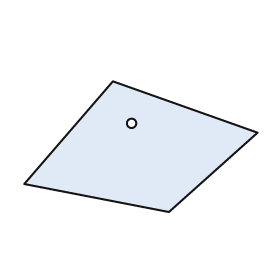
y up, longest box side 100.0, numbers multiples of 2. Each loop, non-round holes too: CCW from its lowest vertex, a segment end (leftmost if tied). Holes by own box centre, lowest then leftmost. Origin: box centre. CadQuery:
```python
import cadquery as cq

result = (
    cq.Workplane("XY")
    .moveTo(12.0, -28.0)
    .lineTo(50.0, 6.0)
    .lineTo(-12.0, 28.0)
    .lineTo(-50.0, -16.0)
    .close()
    .moveTo(-4.0, 10.0)
    .circle(2.0)
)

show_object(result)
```